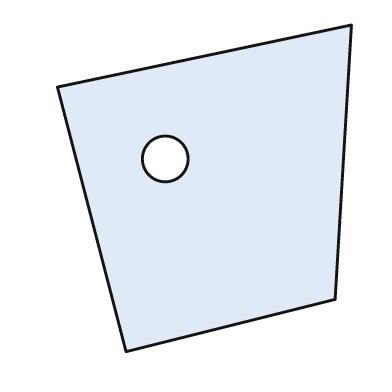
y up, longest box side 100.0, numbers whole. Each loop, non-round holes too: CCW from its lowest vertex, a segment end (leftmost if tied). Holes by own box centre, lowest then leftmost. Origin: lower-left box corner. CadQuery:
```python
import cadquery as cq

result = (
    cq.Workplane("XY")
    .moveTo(21.0, 0.0)
    .lineTo(85.0, 16.0)
    .lineTo(90.0, 100.0)
    .lineTo(0.0, 81.0)
    .close()
    .moveTo(33.0, 59.0)
    .circle(7.0)
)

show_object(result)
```